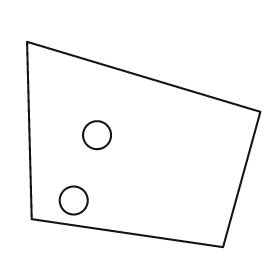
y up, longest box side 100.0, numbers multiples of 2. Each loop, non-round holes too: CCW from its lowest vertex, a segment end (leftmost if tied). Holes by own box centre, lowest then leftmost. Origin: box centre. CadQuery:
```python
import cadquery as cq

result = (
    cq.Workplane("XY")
    .moveTo(34.0, -44.0)
    .lineTo(50.0, 14.0)
    .lineTo(-50.0, 44.0)
    .lineTo(-48.0, -32.0)
    .close()
    .moveTo(-30.0, -24.0)
    .circle(6.0)
    .moveTo(-20.0, 4.0)
    .circle(6.0)
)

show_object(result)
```